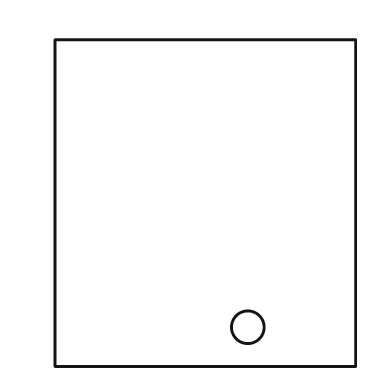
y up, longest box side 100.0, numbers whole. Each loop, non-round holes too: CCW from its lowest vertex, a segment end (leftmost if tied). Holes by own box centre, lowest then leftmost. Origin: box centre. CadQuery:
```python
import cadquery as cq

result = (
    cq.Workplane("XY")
    .moveTo(-46.0, -50.0)
    .lineTo(46.0, -50.0)
    .lineTo(46.0, 50.0)
    .lineTo(-46.0, 50.0)
    .close()
    .moveTo(13.0, -38.0)
    .circle(5.0)
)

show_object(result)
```